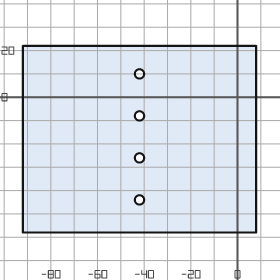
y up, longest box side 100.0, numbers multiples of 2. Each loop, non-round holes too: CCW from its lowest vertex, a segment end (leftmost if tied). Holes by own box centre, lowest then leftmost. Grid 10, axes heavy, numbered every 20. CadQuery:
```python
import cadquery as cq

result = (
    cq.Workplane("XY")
    .moveTo(-92.0, -58.0)
    .lineTo(8.0, -58.0)
    .lineTo(8.0, 22.0)
    .lineTo(-92.0, 22.0)
    .close()
    .moveTo(-42.0, -44.0)
    .circle(2.0)
    .moveTo(-42.0, -26.0)
    .circle(2.0)
    .moveTo(-42.0, -8.0)
    .circle(2.0)
    .moveTo(-42.0, 10.0)
    .circle(2.0)
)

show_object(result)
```